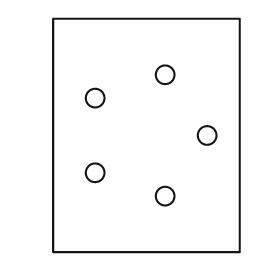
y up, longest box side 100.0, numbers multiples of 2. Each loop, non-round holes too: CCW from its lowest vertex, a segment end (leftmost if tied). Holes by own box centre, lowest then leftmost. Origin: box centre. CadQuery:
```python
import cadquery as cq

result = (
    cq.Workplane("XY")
    .moveTo(-40.0, -50.0)
    .lineTo(40.0, -50.0)
    .lineTo(40.0, 50.0)
    .lineTo(-40.0, 50.0)
    .close()
    .moveTo(8.0, -26.0)
    .circle(4.0)
    .moveTo(-22.0, -16.0)
    .circle(4.0)
    .moveTo(26.0, 0.0)
    .circle(4.0)
    .moveTo(-22.0, 16.0)
    .circle(4.0)
    .moveTo(8.0, 26.0)
    .circle(4.0)
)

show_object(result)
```